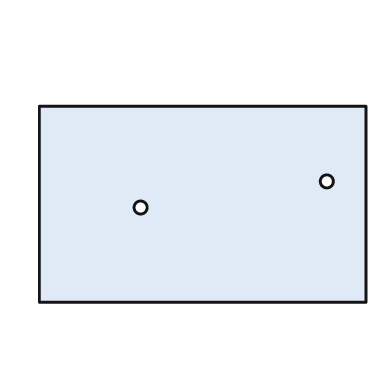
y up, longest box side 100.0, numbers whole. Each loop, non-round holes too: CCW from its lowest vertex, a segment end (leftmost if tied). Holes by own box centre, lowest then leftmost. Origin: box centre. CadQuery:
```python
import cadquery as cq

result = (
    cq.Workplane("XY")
    .moveTo(-50.0, -30.0)
    .lineTo(50.0, -30.0)
    .lineTo(50.0, 30.0)
    .lineTo(-50.0, 30.0)
    .close()
    .moveTo(-19.0, -1.0)
    .circle(2.0)
    .moveTo(38.0, 7.0)
    .circle(2.0)
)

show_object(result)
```